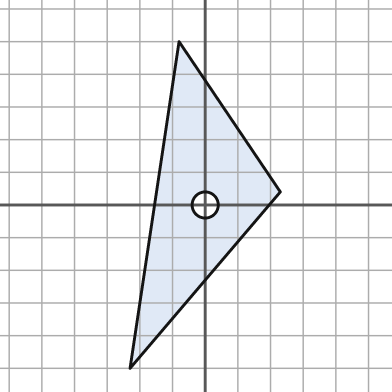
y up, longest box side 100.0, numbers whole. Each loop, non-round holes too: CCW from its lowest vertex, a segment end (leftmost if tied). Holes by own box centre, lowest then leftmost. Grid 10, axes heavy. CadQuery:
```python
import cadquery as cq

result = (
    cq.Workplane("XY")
    .moveTo(-23.0, -50.0)
    .lineTo(23.0, 4.0)
    .lineTo(-8.0, 50.0)
    .close()
    .moveTo(0.0, 0.0)
    .circle(4.0)
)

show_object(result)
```